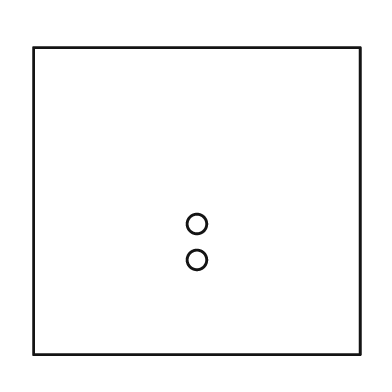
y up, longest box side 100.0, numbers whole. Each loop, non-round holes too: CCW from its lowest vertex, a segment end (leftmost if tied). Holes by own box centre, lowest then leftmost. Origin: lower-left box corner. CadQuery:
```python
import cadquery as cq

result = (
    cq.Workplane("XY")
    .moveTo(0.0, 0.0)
    .lineTo(100.0, 0.0)
    .lineTo(100.0, 94.0)
    .lineTo(0.0, 94.0)
    .close()
    .moveTo(50.0, 29.0)
    .circle(3.0)
    .moveTo(50.0, 40.0)
    .circle(3.0)
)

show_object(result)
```